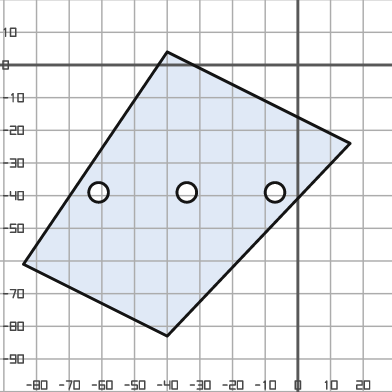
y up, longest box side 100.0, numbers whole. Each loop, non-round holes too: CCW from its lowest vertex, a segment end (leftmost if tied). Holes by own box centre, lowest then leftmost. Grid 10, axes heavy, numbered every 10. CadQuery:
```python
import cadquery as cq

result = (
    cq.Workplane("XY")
    .moveTo(-40.0, -83.0)
    .lineTo(16.0, -24.0)
    .lineTo(-40.0, 4.0)
    .lineTo(-84.0, -61.0)
    .close()
    .moveTo(-61.0, -39.0)
    .circle(3.0)
    .moveTo(-34.0, -39.0)
    .circle(3.0)
    .moveTo(-7.0, -39.0)
    .circle(3.0)
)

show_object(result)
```